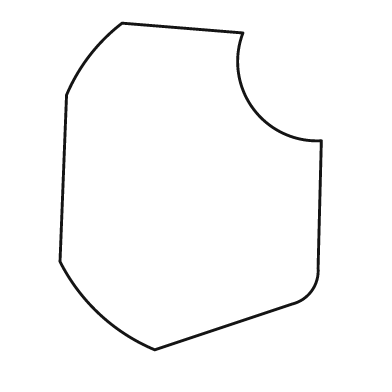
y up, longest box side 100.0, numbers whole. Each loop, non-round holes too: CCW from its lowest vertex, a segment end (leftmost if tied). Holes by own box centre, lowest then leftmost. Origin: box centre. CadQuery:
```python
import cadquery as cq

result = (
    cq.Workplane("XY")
    .moveTo(-11.0, -50.0)
    .lineTo(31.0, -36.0)
    .threePointArc((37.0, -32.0), (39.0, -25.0))
    .lineTo(40.0, 14.0)
    .threePointArc((19.0, 24.0), (16.0, 47.0))
    .lineTo(-21.0, 50.0)
    .threePointArc((-31.0, 40.0), (-38.0, 28.0))
    .lineTo(-40.0, -23.0)
    .threePointArc((-28.0, -39.0), (-11.0, -50.0))
    .close()
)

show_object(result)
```